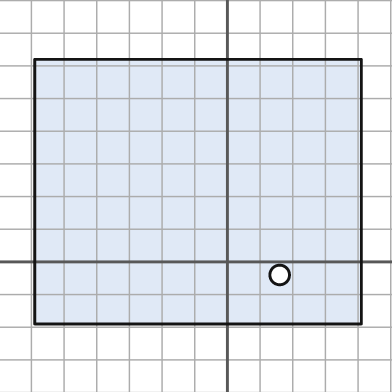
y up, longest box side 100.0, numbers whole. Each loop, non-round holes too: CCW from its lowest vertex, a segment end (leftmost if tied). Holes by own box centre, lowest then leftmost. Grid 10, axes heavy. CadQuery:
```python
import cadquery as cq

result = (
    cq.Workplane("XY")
    .moveTo(-59.0, -19.0)
    .lineTo(41.0, -19.0)
    .lineTo(41.0, 62.0)
    .lineTo(-59.0, 62.0)
    .close()
    .moveTo(16.0, -4.0)
    .circle(3.0)
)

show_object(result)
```